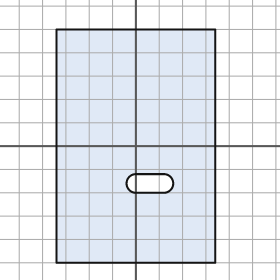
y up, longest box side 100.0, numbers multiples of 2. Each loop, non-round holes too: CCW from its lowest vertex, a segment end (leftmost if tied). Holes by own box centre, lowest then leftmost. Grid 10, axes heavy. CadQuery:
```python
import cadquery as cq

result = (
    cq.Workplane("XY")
    .moveTo(-34.0, -50.0)
    .lineTo(34.0, -50.0)
    .lineTo(34.0, 50.0)
    .lineTo(-34.0, 50.0)
    .close()
    .moveTo(0.0, -20.0)
    .lineTo(12.0, -20.0)
    .threePointArc((16.0, -16.0), (12.0, -12.0))
    .lineTo(0.0, -12.0)
    .threePointArc((-4.0, -16.0), (0.0, -20.0))
    .close()
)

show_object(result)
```